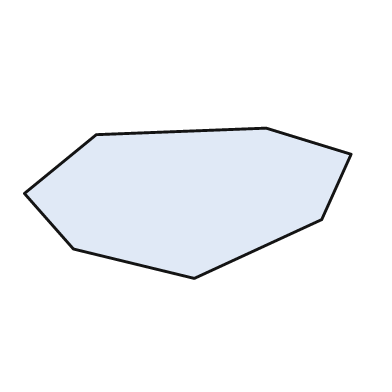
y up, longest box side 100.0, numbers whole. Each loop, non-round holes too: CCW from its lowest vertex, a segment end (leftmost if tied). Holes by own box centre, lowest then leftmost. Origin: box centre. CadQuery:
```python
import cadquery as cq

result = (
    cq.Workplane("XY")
    .moveTo(2.0, -23.0)
    .lineTo(41.0, -5.0)
    .lineTo(50.0, 15.0)
    .lineTo(24.0, 23.0)
    .lineTo(-28.0, 21.0)
    .lineTo(-50.0, 3.0)
    .lineTo(-35.0, -14.0)
    .close()
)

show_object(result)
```